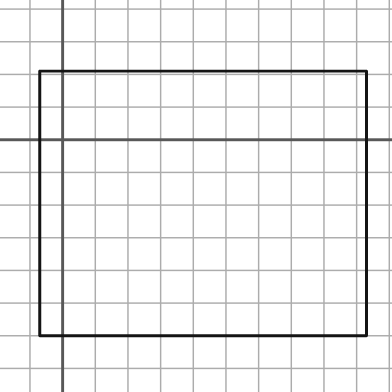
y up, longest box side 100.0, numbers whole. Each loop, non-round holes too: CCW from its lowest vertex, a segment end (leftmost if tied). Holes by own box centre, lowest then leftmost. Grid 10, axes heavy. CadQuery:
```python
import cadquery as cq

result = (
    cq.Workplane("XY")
    .moveTo(-7.0, -60.0)
    .lineTo(93.0, -60.0)
    .lineTo(93.0, 21.0)
    .lineTo(-7.0, 21.0)
    .close()
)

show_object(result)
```